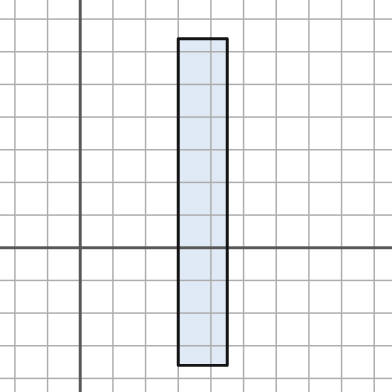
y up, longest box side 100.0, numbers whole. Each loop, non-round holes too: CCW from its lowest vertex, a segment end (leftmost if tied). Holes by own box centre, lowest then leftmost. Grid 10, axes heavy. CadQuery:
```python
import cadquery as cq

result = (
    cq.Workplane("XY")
    .moveTo(30.0, -36.0)
    .lineTo(45.0, -36.0)
    .lineTo(45.0, 64.0)
    .lineTo(30.0, 64.0)
    .close()
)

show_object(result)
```